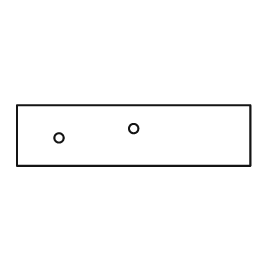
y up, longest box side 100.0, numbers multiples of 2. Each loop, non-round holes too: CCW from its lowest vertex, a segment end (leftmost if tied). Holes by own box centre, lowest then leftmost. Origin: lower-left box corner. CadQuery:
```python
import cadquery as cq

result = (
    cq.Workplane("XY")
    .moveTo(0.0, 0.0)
    .lineTo(100.0, 0.0)
    .lineTo(100.0, 26.0)
    .lineTo(0.0, 26.0)
    .close()
    .moveTo(18.0, 12.0)
    .circle(2.0)
    .moveTo(50.0, 16.0)
    .circle(2.0)
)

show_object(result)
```